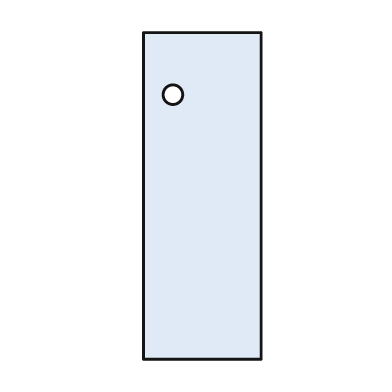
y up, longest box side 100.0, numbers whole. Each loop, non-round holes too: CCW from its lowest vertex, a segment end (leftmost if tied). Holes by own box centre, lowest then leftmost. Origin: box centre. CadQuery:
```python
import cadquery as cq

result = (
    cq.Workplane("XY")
    .moveTo(-18.0, -50.0)
    .lineTo(18.0, -50.0)
    .lineTo(18.0, 50.0)
    .lineTo(-18.0, 50.0)
    .close()
    .moveTo(-9.0, 31.0)
    .circle(3.0)
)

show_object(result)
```